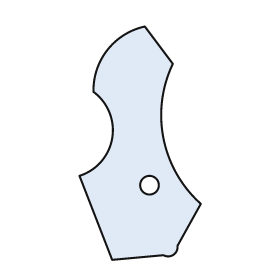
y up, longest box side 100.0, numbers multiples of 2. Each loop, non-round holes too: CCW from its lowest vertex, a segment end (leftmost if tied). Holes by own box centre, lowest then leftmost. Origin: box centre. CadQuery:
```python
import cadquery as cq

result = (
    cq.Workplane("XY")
    .moveTo(-12.0, -50.0)
    .lineTo(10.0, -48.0)
    .threePointArc((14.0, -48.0), (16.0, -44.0))
    .lineTo(26.0, -26.0)
    .threePointArc((10.0, 2.0), (14.0, 34.0))
    .lineTo(2.0, 50.0)
    .threePointArc((-14.0, 40.0), (-20.0, 22.0))
    .threePointArc((-12.0, 2.0), (-26.0, -14.0))
    .close()
    .moveTo(4.0, -18.0)
    .circle(4.0)
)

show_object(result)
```